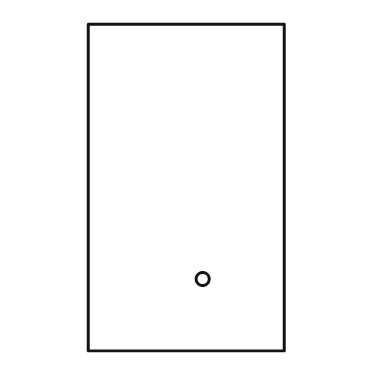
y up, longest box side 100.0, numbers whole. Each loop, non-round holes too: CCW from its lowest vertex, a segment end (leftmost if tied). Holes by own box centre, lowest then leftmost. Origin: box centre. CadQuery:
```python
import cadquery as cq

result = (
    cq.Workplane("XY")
    .moveTo(-30.0, -50.0)
    .lineTo(30.0, -50.0)
    .lineTo(30.0, 50.0)
    .lineTo(-30.0, 50.0)
    .close()
    .moveTo(5.0, -28.0)
    .circle(2.0)
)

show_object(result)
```